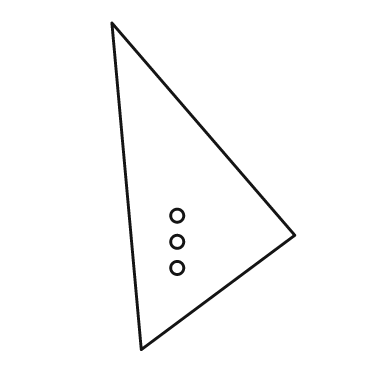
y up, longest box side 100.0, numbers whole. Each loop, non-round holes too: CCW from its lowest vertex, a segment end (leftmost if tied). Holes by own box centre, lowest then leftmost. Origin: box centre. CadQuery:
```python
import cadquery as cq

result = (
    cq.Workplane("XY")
    .moveTo(-19.0, -50.0)
    .lineTo(28.0, -15.0)
    .lineTo(-28.0, 50.0)
    .close()
    .moveTo(-8.0, -25.0)
    .circle(2.0)
    .moveTo(-8.0, -17.0)
    .circle(2.0)
    .moveTo(-8.0, -9.0)
    .circle(2.0)
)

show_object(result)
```